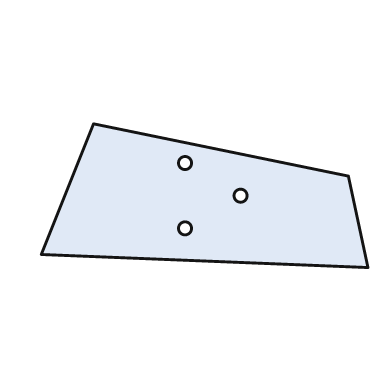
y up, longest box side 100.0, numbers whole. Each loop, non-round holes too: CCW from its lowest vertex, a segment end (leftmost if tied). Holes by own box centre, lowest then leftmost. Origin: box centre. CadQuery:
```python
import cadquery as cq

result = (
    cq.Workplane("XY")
    .moveTo(50.0, -22.0)
    .lineTo(44.0, 6.0)
    .lineTo(-34.0, 22.0)
    .lineTo(-50.0, -18.0)
    .close()
    .moveTo(-6.0, -10.0)
    .circle(2.0)
    .moveTo(11.0, 0.0)
    .circle(2.0)
    .moveTo(-6.0, 10.0)
    .circle(2.0)
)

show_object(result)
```